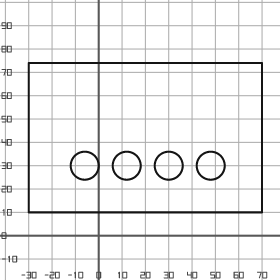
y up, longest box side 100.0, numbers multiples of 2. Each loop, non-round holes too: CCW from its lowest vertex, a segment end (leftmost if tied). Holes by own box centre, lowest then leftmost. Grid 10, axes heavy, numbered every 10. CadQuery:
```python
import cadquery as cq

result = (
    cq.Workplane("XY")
    .moveTo(-30.0, 10.0)
    .lineTo(70.0, 10.0)
    .lineTo(70.0, 74.0)
    .lineTo(-30.0, 74.0)
    .close()
    .moveTo(-6.0, 30.0)
    .circle(6.0)
    .moveTo(12.0, 30.0)
    .circle(6.0)
    .moveTo(30.0, 30.0)
    .circle(6.0)
    .moveTo(48.0, 30.0)
    .circle(6.0)
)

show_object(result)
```